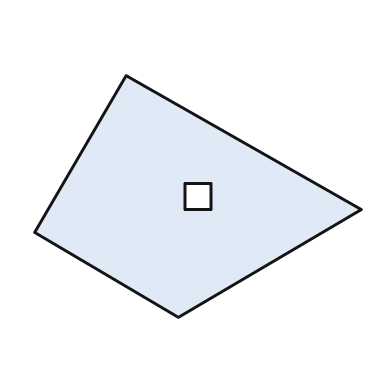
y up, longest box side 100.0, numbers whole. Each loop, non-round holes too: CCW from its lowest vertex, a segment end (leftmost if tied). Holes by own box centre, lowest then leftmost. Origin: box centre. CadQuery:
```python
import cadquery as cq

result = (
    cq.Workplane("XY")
    .moveTo(-6.0, -37.0)
    .lineTo(50.0, -4.0)
    .lineTo(-22.0, 37.0)
    .lineTo(-50.0, -11.0)
    .close()
    .moveTo(-4.0, -4.0)
    .lineTo(4.0, -4.0)
    .lineTo(4.0, 4.0)
    .lineTo(-4.0, 4.0)
    .close()
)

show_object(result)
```